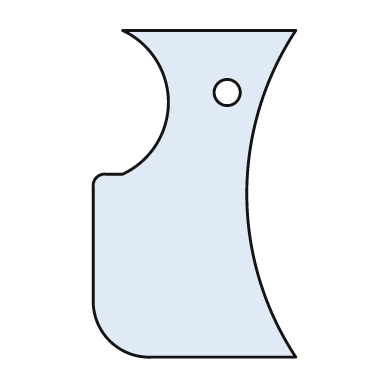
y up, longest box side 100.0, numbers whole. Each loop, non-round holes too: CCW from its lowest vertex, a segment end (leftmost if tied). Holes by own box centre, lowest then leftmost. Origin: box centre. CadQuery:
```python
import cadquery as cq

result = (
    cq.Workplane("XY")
    .moveTo(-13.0, -50.0)
    .lineTo(31.0, -50.0)
    .threePointArc((16.0, 0.0), (31.0, 50.0))
    .lineTo(-22.0, 50.0)
    .threePointArc((-8.0, 28.0), (-22.0, 6.0))
    .lineTo(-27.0, 6.0)
    .threePointArc((-30.0, 5.0), (-31.0, 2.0))
    .lineTo(-31.0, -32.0)
    .threePointArc((-26.0, -45.0), (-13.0, -50.0))
    .close()
    .moveTo(10.0, 31.0)
    .circle(4.0)
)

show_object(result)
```